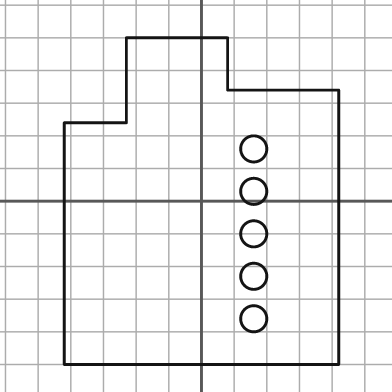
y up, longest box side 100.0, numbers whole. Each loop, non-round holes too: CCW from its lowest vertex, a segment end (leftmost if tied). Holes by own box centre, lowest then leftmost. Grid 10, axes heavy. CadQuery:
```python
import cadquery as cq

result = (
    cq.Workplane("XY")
    .moveTo(-42.0, -50.0)
    .lineTo(42.0, -50.0)
    .lineTo(42.0, 34.0)
    .lineTo(8.0, 34.0)
    .lineTo(8.0, 50.0)
    .lineTo(-23.0, 50.0)
    .lineTo(-23.0, 24.0)
    .lineTo(-42.0, 24.0)
    .close()
    .moveTo(16.0, -36.0)
    .circle(4.0)
    .moveTo(16.0, -23.0)
    .circle(4.0)
    .moveTo(16.0, -10.0)
    .circle(4.0)
    .moveTo(16.0, 3.0)
    .circle(4.0)
    .moveTo(16.0, 16.0)
    .circle(4.0)
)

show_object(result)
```